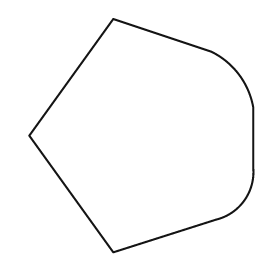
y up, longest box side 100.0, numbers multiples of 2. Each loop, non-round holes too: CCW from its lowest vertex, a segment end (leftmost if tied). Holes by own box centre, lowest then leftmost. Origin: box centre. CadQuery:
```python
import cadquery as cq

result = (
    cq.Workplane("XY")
    .moveTo(-12.0, -50.0)
    .lineTo(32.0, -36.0)
    .threePointArc((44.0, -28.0), (48.0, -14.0))
    .lineTo(48.0, 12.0)
    .threePointArc((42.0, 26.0), (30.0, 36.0))
    .lineTo(-12.0, 50.0)
    .lineTo(-48.0, 0.0)
    .close()
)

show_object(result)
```